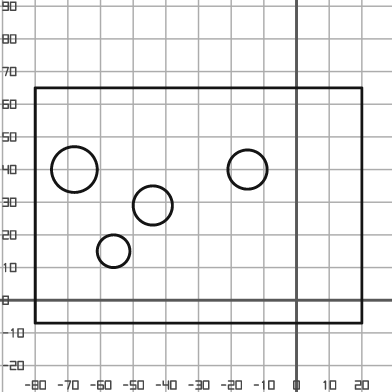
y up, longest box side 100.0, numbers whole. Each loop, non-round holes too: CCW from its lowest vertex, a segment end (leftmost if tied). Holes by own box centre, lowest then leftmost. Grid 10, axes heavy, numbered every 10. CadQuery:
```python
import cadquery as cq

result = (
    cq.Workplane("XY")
    .moveTo(-80.0, -7.0)
    .lineTo(20.0, -7.0)
    .lineTo(20.0, 65.0)
    .lineTo(-80.0, 65.0)
    .close()
    .moveTo(-56.0, 15.0)
    .circle(5.0)
    .moveTo(-44.0, 29.0)
    .circle(6.0)
    .moveTo(-68.0, 40.0)
    .circle(7.0)
    .moveTo(-15.0, 40.0)
    .circle(6.0)
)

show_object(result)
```